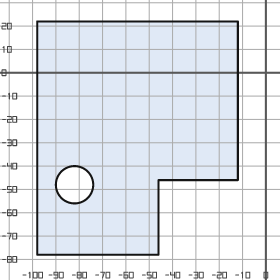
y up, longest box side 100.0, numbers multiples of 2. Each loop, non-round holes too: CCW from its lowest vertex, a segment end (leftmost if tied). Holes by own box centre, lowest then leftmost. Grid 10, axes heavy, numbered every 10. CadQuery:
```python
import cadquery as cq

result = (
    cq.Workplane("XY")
    .moveTo(-98.0, -78.0)
    .lineTo(-46.0, -78.0)
    .lineTo(-46.0, -46.0)
    .lineTo(-12.0, -46.0)
    .lineTo(-12.0, 22.0)
    .lineTo(-98.0, 22.0)
    .close()
    .moveTo(-82.0, -48.0)
    .circle(8.0)
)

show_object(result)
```